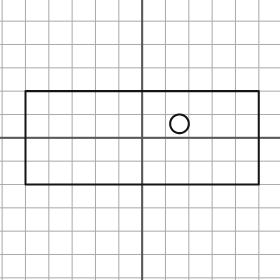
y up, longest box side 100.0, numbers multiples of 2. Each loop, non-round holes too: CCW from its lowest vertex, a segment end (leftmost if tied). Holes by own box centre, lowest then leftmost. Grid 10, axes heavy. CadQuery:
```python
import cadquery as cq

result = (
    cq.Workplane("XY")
    .moveTo(-50.0, -20.0)
    .lineTo(50.0, -20.0)
    .lineTo(50.0, 20.0)
    .lineTo(-50.0, 20.0)
    .close()
    .moveTo(16.0, 6.0)
    .circle(4.0)
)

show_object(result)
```